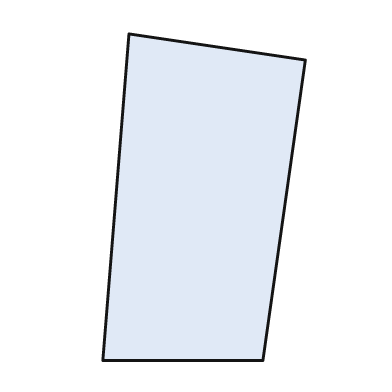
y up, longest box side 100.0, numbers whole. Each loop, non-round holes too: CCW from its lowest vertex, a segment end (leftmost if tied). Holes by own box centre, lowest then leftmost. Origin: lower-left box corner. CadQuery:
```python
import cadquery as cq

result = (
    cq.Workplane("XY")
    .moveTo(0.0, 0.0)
    .lineTo(49.0, 0.0)
    .lineTo(62.0, 92.0)
    .lineTo(8.0, 100.0)
    .close()
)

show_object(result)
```